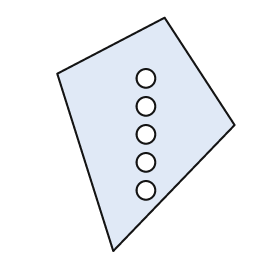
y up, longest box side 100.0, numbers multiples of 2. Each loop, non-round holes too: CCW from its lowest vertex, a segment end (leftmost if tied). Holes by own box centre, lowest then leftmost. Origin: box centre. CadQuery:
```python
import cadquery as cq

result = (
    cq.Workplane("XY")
    .moveTo(-14.0, -50.0)
    .lineTo(38.0, 4.0)
    .lineTo(8.0, 50.0)
    .lineTo(-38.0, 26.0)
    .close()
    .moveTo(0.0, -24.0)
    .circle(4.0)
    .moveTo(0.0, -12.0)
    .circle(4.0)
    .moveTo(0.0, 0.0)
    .circle(4.0)
    .moveTo(0.0, 12.0)
    .circle(4.0)
    .moveTo(0.0, 24.0)
    .circle(4.0)
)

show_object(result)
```